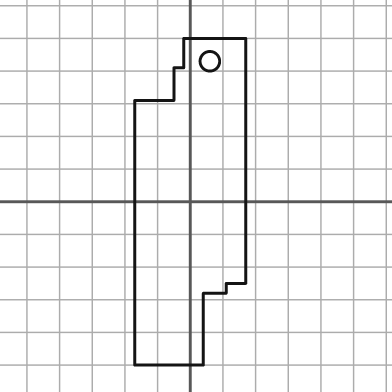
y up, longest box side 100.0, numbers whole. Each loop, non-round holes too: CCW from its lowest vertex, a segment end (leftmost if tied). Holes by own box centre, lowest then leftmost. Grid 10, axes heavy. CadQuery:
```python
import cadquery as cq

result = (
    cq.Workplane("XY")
    .moveTo(-17.0, -50.0)
    .lineTo(4.0, -50.0)
    .lineTo(4.0, -28.0)
    .lineTo(11.0, -28.0)
    .lineTo(11.0, -25.0)
    .lineTo(17.0, -25.0)
    .lineTo(17.0, 50.0)
    .lineTo(-2.0, 50.0)
    .lineTo(-2.0, 41.0)
    .lineTo(-5.0, 41.0)
    .lineTo(-5.0, 31.0)
    .lineTo(-17.0, 31.0)
    .close()
    .moveTo(6.0, 43.0)
    .circle(3.0)
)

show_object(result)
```